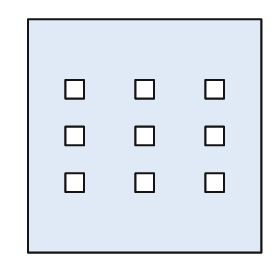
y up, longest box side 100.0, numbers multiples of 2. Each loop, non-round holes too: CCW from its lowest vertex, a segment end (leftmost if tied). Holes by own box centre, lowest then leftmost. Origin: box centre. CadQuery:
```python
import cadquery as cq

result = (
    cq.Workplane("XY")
    .moveTo(-50.0, -50.0)
    .lineTo(50.0, -50.0)
    .lineTo(50.0, 50.0)
    .lineTo(-50.0, 50.0)
    .close()
    .moveTo(-34.0, -24.0)
    .lineTo(-26.0, -24.0)
    .lineTo(-26.0, -16.0)
    .lineTo(-34.0, -16.0)
    .close()
    .moveTo(-4.0, -24.0)
    .lineTo(4.0, -24.0)
    .lineTo(4.0, -16.0)
    .lineTo(-4.0, -16.0)
    .close()
    .moveTo(26.0, -24.0)
    .lineTo(34.0, -24.0)
    .lineTo(34.0, -16.0)
    .lineTo(26.0, -16.0)
    .close()
    .moveTo(-34.0, -4.0)
    .lineTo(-26.0, -4.0)
    .lineTo(-26.0, 4.0)
    .lineTo(-34.0, 4.0)
    .close()
    .moveTo(-4.0, -4.0)
    .lineTo(4.0, -4.0)
    .lineTo(4.0, 4.0)
    .lineTo(-4.0, 4.0)
    .close()
    .moveTo(26.0, -4.0)
    .lineTo(34.0, -4.0)
    .lineTo(34.0, 4.0)
    .lineTo(26.0, 4.0)
    .close()
    .moveTo(-34.0, 16.0)
    .lineTo(-26.0, 16.0)
    .lineTo(-26.0, 24.0)
    .lineTo(-34.0, 24.0)
    .close()
    .moveTo(-4.0, 16.0)
    .lineTo(4.0, 16.0)
    .lineTo(4.0, 24.0)
    .lineTo(-4.0, 24.0)
    .close()
    .moveTo(26.0, 16.0)
    .lineTo(34.0, 16.0)
    .lineTo(34.0, 24.0)
    .lineTo(26.0, 24.0)
    .close()
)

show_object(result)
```